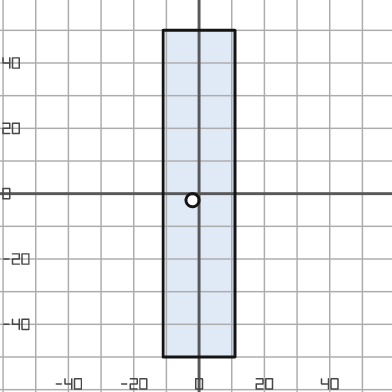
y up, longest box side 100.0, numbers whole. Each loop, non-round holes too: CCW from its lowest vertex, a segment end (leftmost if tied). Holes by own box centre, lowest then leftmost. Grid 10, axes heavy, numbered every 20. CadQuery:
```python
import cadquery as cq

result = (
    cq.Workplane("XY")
    .moveTo(-11.0, -50.0)
    .lineTo(11.0, -50.0)
    .lineTo(11.0, 50.0)
    .lineTo(-11.0, 50.0)
    .close()
    .moveTo(-2.0, -2.0)
    .circle(2.0)
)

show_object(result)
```